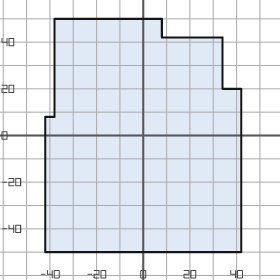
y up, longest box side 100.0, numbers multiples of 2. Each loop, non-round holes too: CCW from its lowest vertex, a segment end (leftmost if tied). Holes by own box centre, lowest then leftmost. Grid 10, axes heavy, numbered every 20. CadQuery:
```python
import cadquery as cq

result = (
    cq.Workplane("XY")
    .moveTo(-42.0, -50.0)
    .lineTo(42.0, -50.0)
    .lineTo(42.0, 20.0)
    .lineTo(34.0, 20.0)
    .lineTo(34.0, 42.0)
    .lineTo(8.0, 42.0)
    .lineTo(8.0, 50.0)
    .lineTo(-38.0, 50.0)
    .lineTo(-38.0, 8.0)
    .lineTo(-42.0, 8.0)
    .close()
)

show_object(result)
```